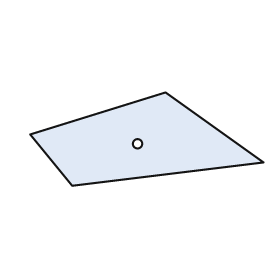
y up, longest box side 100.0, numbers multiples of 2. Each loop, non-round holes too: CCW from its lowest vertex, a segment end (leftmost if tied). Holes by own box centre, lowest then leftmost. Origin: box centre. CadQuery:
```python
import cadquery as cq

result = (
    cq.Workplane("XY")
    .moveTo(-32.0, -20.0)
    .lineTo(50.0, -10.0)
    .lineTo(8.0, 20.0)
    .lineTo(-50.0, 2.0)
    .close()
    .moveTo(-4.0, -2.0)
    .circle(2.0)
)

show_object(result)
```